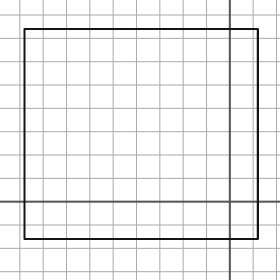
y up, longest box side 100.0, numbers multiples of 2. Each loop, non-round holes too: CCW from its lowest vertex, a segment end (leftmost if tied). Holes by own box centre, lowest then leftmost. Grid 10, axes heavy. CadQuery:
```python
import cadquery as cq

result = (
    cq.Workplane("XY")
    .moveTo(-88.0, -16.0)
    .lineTo(12.0, -16.0)
    .lineTo(12.0, 74.0)
    .lineTo(-88.0, 74.0)
    .close()
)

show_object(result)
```